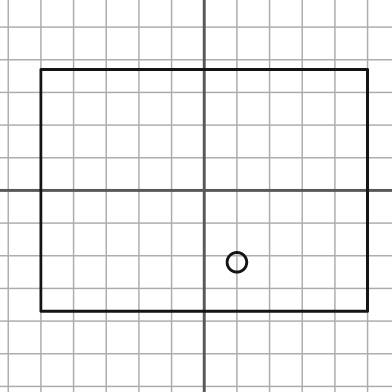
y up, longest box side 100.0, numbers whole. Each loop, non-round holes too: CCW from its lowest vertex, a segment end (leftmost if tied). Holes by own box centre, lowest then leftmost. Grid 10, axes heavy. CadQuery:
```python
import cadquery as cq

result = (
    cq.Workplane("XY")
    .moveTo(-50.0, -37.0)
    .lineTo(50.0, -37.0)
    .lineTo(50.0, 37.0)
    .lineTo(-50.0, 37.0)
    .close()
    .moveTo(10.0, -22.0)
    .circle(3.0)
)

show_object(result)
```